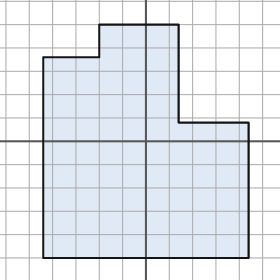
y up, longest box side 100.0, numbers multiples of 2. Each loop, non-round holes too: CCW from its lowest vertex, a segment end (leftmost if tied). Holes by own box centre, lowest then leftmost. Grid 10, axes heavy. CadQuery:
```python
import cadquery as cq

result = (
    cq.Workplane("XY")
    .moveTo(-44.0, -50.0)
    .lineTo(44.0, -50.0)
    .lineTo(44.0, 8.0)
    .lineTo(14.0, 8.0)
    .lineTo(14.0, 50.0)
    .lineTo(-20.0, 50.0)
    .lineTo(-20.0, 36.0)
    .lineTo(-44.0, 36.0)
    .close()
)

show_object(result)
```